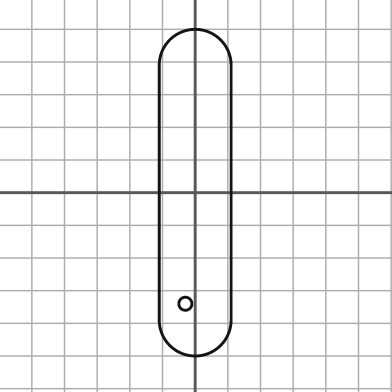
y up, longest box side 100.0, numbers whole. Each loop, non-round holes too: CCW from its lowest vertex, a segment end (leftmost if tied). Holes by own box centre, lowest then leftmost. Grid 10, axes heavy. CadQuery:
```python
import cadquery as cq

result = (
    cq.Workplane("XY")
    .moveTo(-11.0, -39.0)
    .threePointArc((0.0, -50.0), (11.0, -39.0))
    .lineTo(11.0, 39.0)
    .threePointArc((0.0, 50.0), (-11.0, 39.0))
    .close()
    .moveTo(-3.0, -34.0)
    .circle(2.0)
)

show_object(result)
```